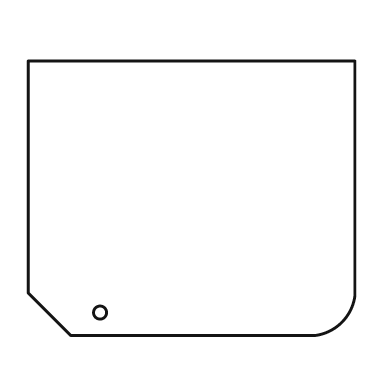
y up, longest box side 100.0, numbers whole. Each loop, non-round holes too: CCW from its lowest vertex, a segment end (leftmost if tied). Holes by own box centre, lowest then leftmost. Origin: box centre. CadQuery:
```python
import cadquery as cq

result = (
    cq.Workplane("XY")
    .moveTo(-37.0, -42.0)
    .lineTo(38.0, -42.0)
    .threePointArc((46.0, -38.0), (50.0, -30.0))
    .lineTo(50.0, 42.0)
    .lineTo(-50.0, 42.0)
    .lineTo(-50.0, -29.0)
    .close()
    .moveTo(-28.0, -35.0)
    .circle(2.0)
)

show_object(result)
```